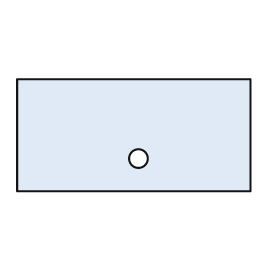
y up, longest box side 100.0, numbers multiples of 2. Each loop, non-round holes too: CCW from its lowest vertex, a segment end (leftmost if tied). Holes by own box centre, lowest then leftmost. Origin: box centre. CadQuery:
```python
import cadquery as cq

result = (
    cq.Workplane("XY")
    .moveTo(-50.0, -24.0)
    .lineTo(50.0, -24.0)
    .lineTo(50.0, 24.0)
    .lineTo(-50.0, 24.0)
    .close()
    .moveTo(2.0, -10.0)
    .circle(4.0)
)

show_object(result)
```